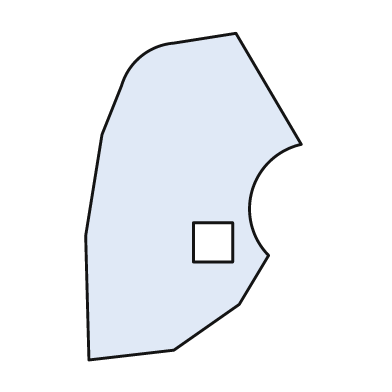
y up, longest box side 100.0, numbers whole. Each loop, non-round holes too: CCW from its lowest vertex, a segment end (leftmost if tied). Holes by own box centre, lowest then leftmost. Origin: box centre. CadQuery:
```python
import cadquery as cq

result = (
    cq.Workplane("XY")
    .moveTo(-32.0, -50.0)
    .lineTo(-6.0, -47.0)
    .lineTo(14.0, -33.0)
    .lineTo(23.0, -18.0)
    .threePointArc((18.0, 2.0), (33.0, 16.0))
    .lineTo(13.0, 50.0)
    .lineTo(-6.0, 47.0)
    .threePointArc((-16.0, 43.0), (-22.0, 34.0))
    .lineTo(-28.0, 19.0)
    .lineTo(-33.0, -12.0)
    .close()
    .moveTo(0.0, -20.0)
    .lineTo(12.0, -20.0)
    .lineTo(12.0, -8.0)
    .lineTo(0.0, -8.0)
    .close()
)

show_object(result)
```